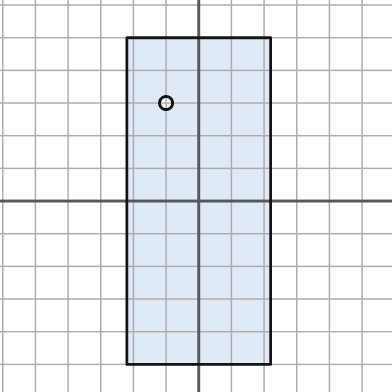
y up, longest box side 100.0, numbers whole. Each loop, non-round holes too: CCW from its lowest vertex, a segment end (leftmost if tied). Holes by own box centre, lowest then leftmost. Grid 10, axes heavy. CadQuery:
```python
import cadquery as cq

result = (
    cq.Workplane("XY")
    .moveTo(-22.0, -50.0)
    .lineTo(22.0, -50.0)
    .lineTo(22.0, 50.0)
    .lineTo(-22.0, 50.0)
    .close()
    .moveTo(-10.0, 30.0)
    .circle(2.0)
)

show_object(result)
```